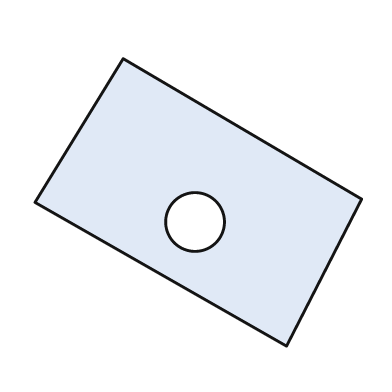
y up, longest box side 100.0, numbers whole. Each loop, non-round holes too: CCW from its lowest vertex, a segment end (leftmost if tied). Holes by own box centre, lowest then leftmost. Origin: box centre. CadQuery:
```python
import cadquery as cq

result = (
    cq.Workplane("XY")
    .moveTo(27.0, -44.0)
    .lineTo(50.0, 1.0)
    .lineTo(-23.0, 44.0)
    .lineTo(-50.0, 0.0)
    .close()
    .moveTo(-1.0, -6.0)
    .circle(9.0)
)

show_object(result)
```